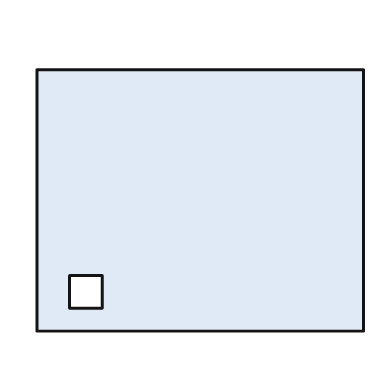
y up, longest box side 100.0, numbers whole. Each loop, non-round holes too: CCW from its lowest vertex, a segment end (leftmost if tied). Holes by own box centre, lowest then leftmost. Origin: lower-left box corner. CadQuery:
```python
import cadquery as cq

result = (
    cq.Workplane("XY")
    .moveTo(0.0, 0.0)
    .lineTo(100.0, 0.0)
    .lineTo(100.0, 80.0)
    .lineTo(0.0, 80.0)
    .close()
    .moveTo(10.0, 7.0)
    .lineTo(20.0, 7.0)
    .lineTo(20.0, 17.0)
    .lineTo(10.0, 17.0)
    .close()
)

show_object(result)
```